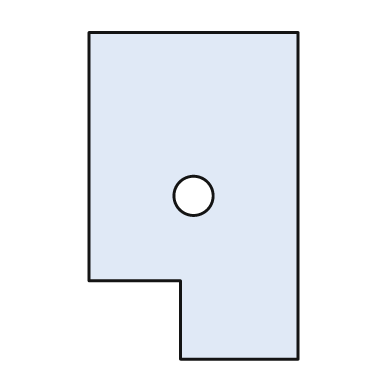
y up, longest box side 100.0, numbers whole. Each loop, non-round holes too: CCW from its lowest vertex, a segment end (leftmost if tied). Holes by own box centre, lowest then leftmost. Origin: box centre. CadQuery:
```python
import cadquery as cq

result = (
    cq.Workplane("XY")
    .moveTo(-4.0, -50.0)
    .lineTo(32.0, -50.0)
    .lineTo(32.0, 50.0)
    .lineTo(-32.0, 50.0)
    .lineTo(-32.0, -26.0)
    .lineTo(-4.0, -26.0)
    .close()
    .moveTo(0.0, 0.0)
    .circle(6.0)
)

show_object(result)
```